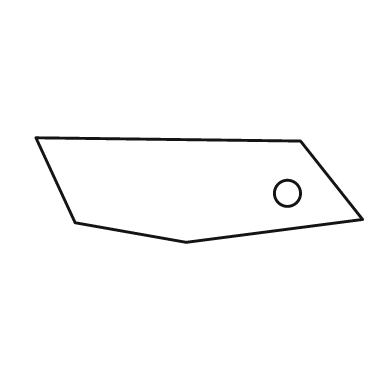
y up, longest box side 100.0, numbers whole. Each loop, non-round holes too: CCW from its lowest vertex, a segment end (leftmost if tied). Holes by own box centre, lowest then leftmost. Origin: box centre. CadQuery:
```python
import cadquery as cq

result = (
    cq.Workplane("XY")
    .moveTo(-4.0, -16.0)
    .lineTo(50.0, -9.0)
    .lineTo(31.0, 15.0)
    .lineTo(-50.0, 16.0)
    .lineTo(-38.0, -10.0)
    .close()
    .moveTo(27.0, -1.0)
    .circle(4.0)
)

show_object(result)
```